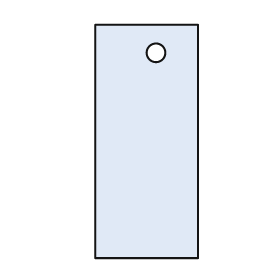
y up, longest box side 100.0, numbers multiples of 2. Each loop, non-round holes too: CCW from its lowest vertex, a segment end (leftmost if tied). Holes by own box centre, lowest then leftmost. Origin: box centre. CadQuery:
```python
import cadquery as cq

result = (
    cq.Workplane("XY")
    .moveTo(-22.0, -50.0)
    .lineTo(22.0, -50.0)
    .lineTo(22.0, 50.0)
    .lineTo(-22.0, 50.0)
    .close()
    .moveTo(4.0, 38.0)
    .circle(4.0)
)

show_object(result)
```